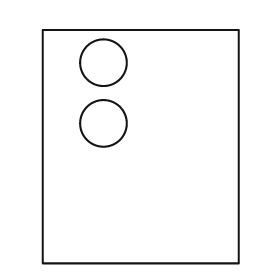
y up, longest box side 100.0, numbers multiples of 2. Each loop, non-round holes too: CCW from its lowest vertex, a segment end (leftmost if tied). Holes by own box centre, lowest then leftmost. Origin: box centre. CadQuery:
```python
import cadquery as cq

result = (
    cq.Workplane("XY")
    .moveTo(-42.0, -50.0)
    .lineTo(42.0, -50.0)
    .lineTo(42.0, 50.0)
    .lineTo(-42.0, 50.0)
    .close()
    .moveTo(-16.0, 10.0)
    .circle(10.0)
    .moveTo(-16.0, 36.0)
    .circle(10.0)
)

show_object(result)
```